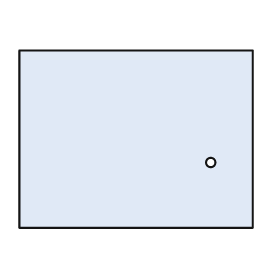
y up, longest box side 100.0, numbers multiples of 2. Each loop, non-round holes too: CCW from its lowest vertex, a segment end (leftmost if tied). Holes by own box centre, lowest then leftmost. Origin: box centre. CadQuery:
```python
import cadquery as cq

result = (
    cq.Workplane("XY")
    .moveTo(-50.0, -38.0)
    .lineTo(50.0, -38.0)
    .lineTo(50.0, 38.0)
    .lineTo(-50.0, 38.0)
    .close()
    .moveTo(32.0, -10.0)
    .circle(2.0)
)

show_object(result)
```